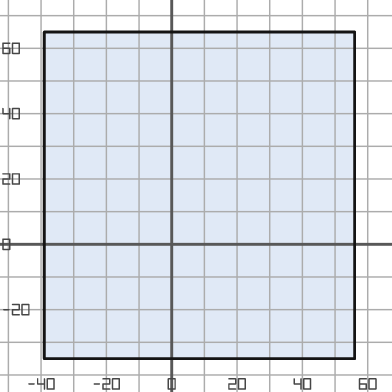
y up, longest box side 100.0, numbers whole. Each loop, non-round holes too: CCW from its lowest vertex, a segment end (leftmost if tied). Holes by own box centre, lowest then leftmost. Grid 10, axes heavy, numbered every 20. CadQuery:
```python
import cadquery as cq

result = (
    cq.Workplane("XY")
    .moveTo(-39.0, -35.0)
    .lineTo(56.0, -35.0)
    .lineTo(56.0, 65.0)
    .lineTo(-39.0, 65.0)
    .close()
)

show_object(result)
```